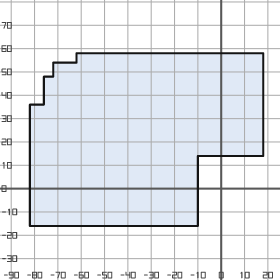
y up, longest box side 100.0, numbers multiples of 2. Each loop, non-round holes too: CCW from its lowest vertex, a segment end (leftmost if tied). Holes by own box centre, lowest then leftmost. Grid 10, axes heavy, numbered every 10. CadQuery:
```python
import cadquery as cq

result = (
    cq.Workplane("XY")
    .moveTo(-82.0, -16.0)
    .lineTo(-10.0, -16.0)
    .lineTo(-10.0, 14.0)
    .lineTo(18.0, 14.0)
    .lineTo(18.0, 58.0)
    .lineTo(-62.0, 58.0)
    .lineTo(-62.0, 54.0)
    .lineTo(-72.0, 54.0)
    .lineTo(-72.0, 48.0)
    .lineTo(-76.0, 48.0)
    .lineTo(-76.0, 36.0)
    .lineTo(-82.0, 36.0)
    .close()
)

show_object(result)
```